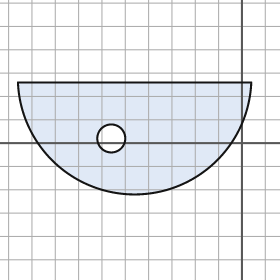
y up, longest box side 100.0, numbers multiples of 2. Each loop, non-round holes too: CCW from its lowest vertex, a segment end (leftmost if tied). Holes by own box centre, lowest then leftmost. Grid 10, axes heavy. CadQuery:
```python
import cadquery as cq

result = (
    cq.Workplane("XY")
    .moveTo(-96.0, 26.0)
    .threePointArc((-46.0, -22.0), (4.0, 26.0))
    .close()
    .moveTo(-56.0, 2.0)
    .circle(6.0)
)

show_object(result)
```